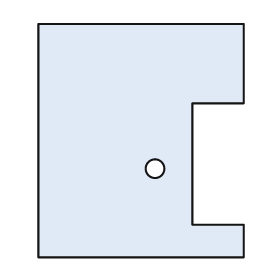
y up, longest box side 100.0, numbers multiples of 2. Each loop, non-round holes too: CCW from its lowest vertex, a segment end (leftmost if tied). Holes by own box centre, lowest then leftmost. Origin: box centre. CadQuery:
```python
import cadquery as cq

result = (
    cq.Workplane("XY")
    .moveTo(-44.0, -50.0)
    .lineTo(44.0, -50.0)
    .lineTo(44.0, -36.0)
    .lineTo(22.0, -36.0)
    .lineTo(22.0, 16.0)
    .lineTo(44.0, 16.0)
    .lineTo(44.0, 50.0)
    .lineTo(-44.0, 50.0)
    .close()
    .moveTo(6.0, -12.0)
    .circle(4.0)
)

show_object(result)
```